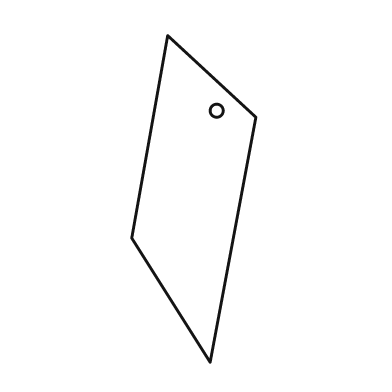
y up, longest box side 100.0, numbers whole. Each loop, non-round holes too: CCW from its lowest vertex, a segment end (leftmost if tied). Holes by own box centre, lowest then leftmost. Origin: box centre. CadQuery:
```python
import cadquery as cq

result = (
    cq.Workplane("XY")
    .moveTo(5.0, -50.0)
    .lineTo(19.0, 25.0)
    .lineTo(-8.0, 50.0)
    .lineTo(-19.0, -12.0)
    .close()
    .moveTo(7.0, 27.0)
    .circle(2.0)
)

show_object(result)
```